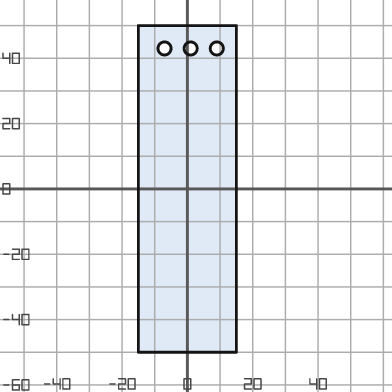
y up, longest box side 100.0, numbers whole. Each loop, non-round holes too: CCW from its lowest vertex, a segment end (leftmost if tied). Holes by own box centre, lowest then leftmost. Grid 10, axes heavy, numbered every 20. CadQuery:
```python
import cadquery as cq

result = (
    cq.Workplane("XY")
    .moveTo(-15.0, -50.0)
    .lineTo(15.0, -50.0)
    .lineTo(15.0, 50.0)
    .lineTo(-15.0, 50.0)
    .close()
    .moveTo(-7.0, 43.0)
    .circle(2.0)
    .moveTo(1.0, 43.0)
    .circle(2.0)
    .moveTo(9.0, 43.0)
    .circle(2.0)
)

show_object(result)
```